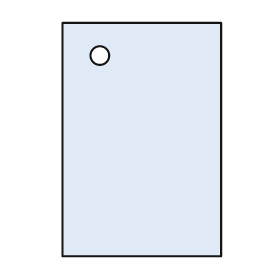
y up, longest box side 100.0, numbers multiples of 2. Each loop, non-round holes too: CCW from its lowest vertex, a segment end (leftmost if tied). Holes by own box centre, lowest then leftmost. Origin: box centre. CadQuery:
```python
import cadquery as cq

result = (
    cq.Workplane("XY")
    .moveTo(-34.0, -50.0)
    .lineTo(34.0, -50.0)
    .lineTo(34.0, 50.0)
    .lineTo(-34.0, 50.0)
    .close()
    .moveTo(-18.0, 36.0)
    .circle(4.0)
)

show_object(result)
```